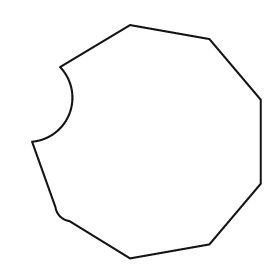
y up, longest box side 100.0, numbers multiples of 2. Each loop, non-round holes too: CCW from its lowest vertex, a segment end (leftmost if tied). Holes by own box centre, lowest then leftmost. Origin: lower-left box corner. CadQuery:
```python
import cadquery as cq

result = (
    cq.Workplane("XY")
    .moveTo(42.0, 0.0)
    .lineTo(76.0, 6.0)
    .lineTo(98.0, 32.0)
    .lineTo(98.0, 68.0)
    .lineTo(76.0, 94.0)
    .lineTo(42.0, 100.0)
    .lineTo(12.0, 82.0)
    .threePointArc((16.0, 62.0), (0.0, 50.0))
    .lineTo(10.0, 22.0)
    .threePointArc((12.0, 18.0), (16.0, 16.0))
    .close()
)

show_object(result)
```